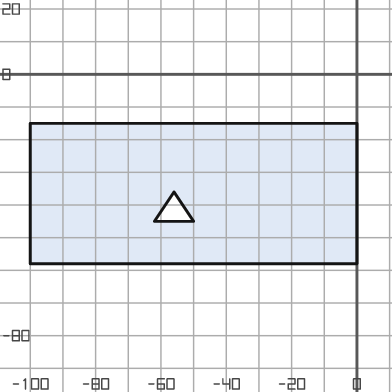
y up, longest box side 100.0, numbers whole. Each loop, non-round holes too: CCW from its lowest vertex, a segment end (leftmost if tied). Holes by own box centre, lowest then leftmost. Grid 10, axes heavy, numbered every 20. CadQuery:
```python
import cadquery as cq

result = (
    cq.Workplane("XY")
    .moveTo(-100.0, -58.0)
    .lineTo(0.0, -58.0)
    .lineTo(0.0, -15.0)
    .lineTo(-100.0, -15.0)
    .close()
    .moveTo(-62.0, -45.0)
    .lineTo(-50.0, -45.0)
    .lineTo(-56.0, -36.0)
    .close()
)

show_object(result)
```